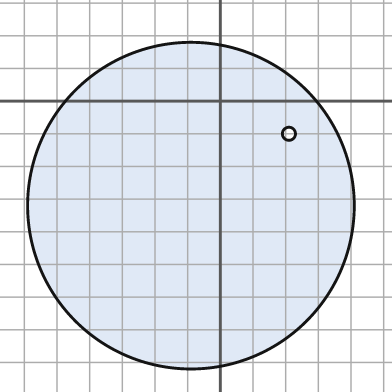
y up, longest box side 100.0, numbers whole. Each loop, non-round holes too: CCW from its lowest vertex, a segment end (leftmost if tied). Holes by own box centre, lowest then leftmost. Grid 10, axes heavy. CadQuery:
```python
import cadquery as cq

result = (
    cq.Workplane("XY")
    .moveTo(-9.0, -32.0)
    .circle(50.0)
    .moveTo(21.0, -10.0)
    .circle(2.0)
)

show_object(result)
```